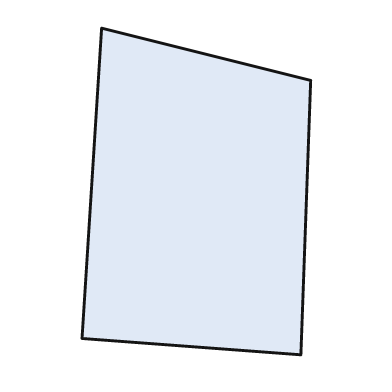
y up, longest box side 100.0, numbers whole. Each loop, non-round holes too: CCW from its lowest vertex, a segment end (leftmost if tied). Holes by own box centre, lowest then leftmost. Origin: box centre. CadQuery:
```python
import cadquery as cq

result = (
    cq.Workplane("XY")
    .moveTo(32.0, -50.0)
    .lineTo(35.0, 34.0)
    .lineTo(-29.0, 50.0)
    .lineTo(-35.0, -45.0)
    .close()
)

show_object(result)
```